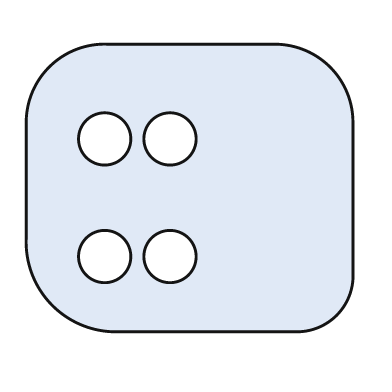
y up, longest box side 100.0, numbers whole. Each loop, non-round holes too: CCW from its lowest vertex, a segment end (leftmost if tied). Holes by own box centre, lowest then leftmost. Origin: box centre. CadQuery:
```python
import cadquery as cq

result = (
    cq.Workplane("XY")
    .moveTo(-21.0, -44.0)
    .lineTo(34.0, -44.0)
    .threePointArc((45.0, -39.0), (50.0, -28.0))
    .lineTo(50.0, 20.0)
    .threePointArc((43.0, 37.0), (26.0, 44.0))
    .lineTo(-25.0, 44.0)
    .threePointArc((-43.0, 37.0), (-50.0, 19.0))
    .lineTo(-50.0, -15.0)
    .threePointArc((-42.0, -36.0), (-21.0, -44.0))
    .close()
    .moveTo(-26.0, -21.0)
    .circle(8.0)
    .moveTo(-6.0, -21.0)
    .circle(8.0)
    .moveTo(-26.0, 15.0)
    .circle(8.0)
    .moveTo(-6.0, 15.0)
    .circle(8.0)
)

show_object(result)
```